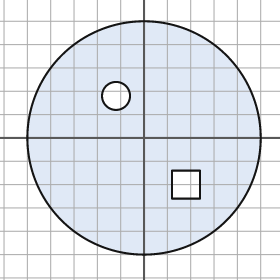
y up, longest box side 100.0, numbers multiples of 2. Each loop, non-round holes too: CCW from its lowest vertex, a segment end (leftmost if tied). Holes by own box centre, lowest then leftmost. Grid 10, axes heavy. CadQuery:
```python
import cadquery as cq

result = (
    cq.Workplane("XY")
    .moveTo(0.0, 0.0)
    .circle(50.0)
    .moveTo(12.0, -26.0)
    .lineTo(24.0, -26.0)
    .lineTo(24.0, -14.0)
    .lineTo(12.0, -14.0)
    .close()
    .moveTo(-12.0, 18.0)
    .circle(6.0)
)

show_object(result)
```